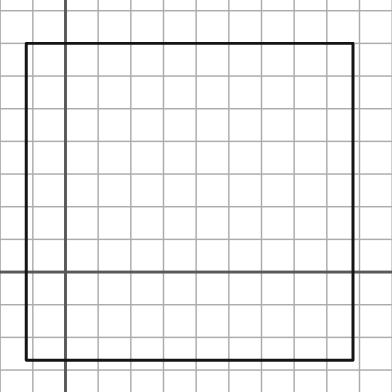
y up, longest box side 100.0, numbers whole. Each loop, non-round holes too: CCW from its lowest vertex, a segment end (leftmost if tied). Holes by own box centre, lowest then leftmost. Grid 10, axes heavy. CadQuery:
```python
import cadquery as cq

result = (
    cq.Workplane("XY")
    .moveTo(-12.0, -27.0)
    .lineTo(88.0, -27.0)
    .lineTo(88.0, 70.0)
    .lineTo(-12.0, 70.0)
    .close()
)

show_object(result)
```